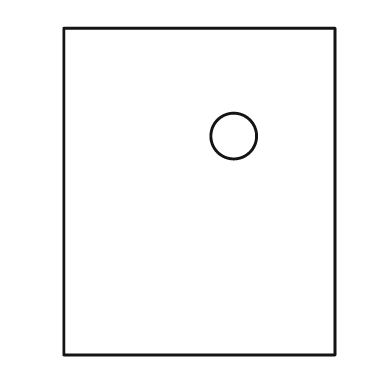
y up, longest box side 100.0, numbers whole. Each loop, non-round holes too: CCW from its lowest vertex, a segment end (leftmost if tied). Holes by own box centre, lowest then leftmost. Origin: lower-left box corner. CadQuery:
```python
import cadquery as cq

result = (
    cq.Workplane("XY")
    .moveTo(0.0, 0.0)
    .lineTo(83.0, 0.0)
    .lineTo(83.0, 100.0)
    .lineTo(0.0, 100.0)
    .close()
    .moveTo(52.0, 67.0)
    .circle(7.0)
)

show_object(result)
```